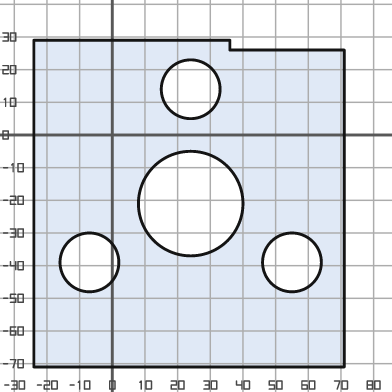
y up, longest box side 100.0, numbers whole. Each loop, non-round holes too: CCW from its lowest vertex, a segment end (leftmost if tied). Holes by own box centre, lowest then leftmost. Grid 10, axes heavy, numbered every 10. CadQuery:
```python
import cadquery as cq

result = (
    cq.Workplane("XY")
    .moveTo(-24.0, -71.0)
    .lineTo(71.0, -71.0)
    .lineTo(71.0, 26.0)
    .lineTo(36.0, 26.0)
    .lineTo(36.0, 29.0)
    .lineTo(-24.0, 29.0)
    .close()
    .moveTo(-7.0, -39.0)
    .circle(9.0)
    .moveTo(55.0, -39.0)
    .circle(9.0)
    .moveTo(24.0, -21.0)
    .circle(16.0)
    .moveTo(24.0, 14.0)
    .circle(9.0)
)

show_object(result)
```